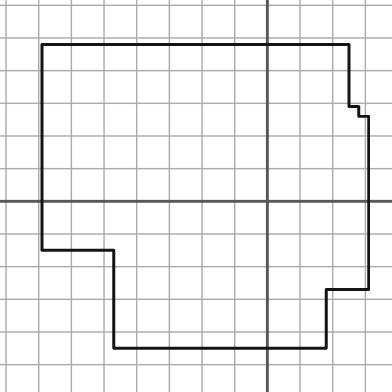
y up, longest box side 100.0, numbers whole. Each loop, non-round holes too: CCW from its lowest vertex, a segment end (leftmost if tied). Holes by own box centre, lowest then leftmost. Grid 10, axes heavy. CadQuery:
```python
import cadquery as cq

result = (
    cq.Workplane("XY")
    .moveTo(-47.0, -45.0)
    .lineTo(18.0, -45.0)
    .lineTo(18.0, -27.0)
    .lineTo(31.0, -27.0)
    .lineTo(31.0, 26.0)
    .lineTo(28.0, 26.0)
    .lineTo(28.0, 29.0)
    .lineTo(25.0, 29.0)
    .lineTo(25.0, 48.0)
    .lineTo(-69.0, 48.0)
    .lineTo(-69.0, -15.0)
    .lineTo(-47.0, -15.0)
    .close()
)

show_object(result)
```